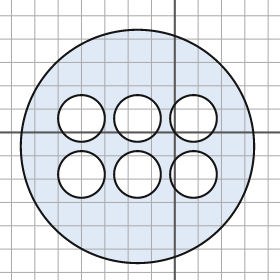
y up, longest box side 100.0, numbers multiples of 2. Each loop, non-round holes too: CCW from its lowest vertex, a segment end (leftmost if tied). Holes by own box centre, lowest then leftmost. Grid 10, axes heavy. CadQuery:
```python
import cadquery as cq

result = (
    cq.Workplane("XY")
    .moveTo(-16.0, -6.0)
    .circle(50.0)
    .moveTo(-40.0, -18.0)
    .circle(10.0)
    .moveTo(-16.0, -18.0)
    .circle(10.0)
    .moveTo(8.0, -18.0)
    .circle(10.0)
    .moveTo(-40.0, 6.0)
    .circle(10.0)
    .moveTo(-16.0, 6.0)
    .circle(10.0)
    .moveTo(8.0, 6.0)
    .circle(10.0)
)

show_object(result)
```